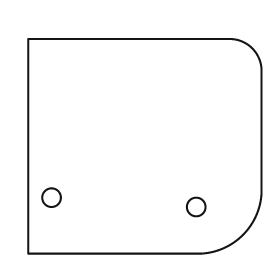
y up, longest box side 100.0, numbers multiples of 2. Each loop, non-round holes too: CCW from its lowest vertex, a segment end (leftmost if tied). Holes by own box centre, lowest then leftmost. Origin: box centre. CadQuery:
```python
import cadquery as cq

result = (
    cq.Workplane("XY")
    .moveTo(-50.0, -46.0)
    .lineTo(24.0, -46.0)
    .threePointArc((42.0, -38.0), (50.0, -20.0))
    .lineTo(50.0, 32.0)
    .threePointArc((46.0, 42.0), (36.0, 46.0))
    .lineTo(-50.0, 46.0)
    .close()
    .moveTo(22.0, -26.0)
    .circle(4.0)
    .moveTo(-40.0, -22.0)
    .circle(4.0)
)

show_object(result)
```